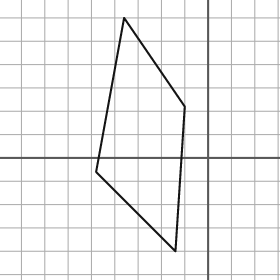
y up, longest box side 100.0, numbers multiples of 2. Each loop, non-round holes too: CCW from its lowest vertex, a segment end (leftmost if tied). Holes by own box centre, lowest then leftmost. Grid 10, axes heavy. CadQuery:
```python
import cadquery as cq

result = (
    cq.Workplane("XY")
    .moveTo(-14.0, -40.0)
    .lineTo(-10.0, 22.0)
    .lineTo(-36.0, 60.0)
    .lineTo(-48.0, -6.0)
    .close()
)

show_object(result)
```